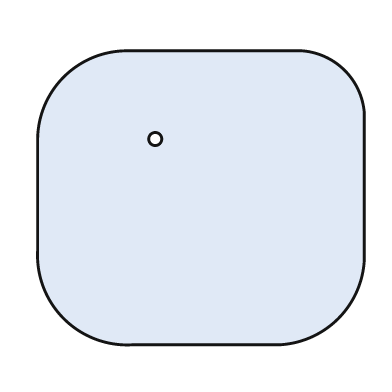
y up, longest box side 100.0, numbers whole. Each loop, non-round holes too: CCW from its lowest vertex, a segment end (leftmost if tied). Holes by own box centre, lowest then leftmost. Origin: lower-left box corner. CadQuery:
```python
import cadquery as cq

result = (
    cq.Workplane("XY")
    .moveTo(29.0, 0.0)
    .lineTo(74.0, 0.0)
    .threePointArc((92.0, 8.0), (100.0, 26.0))
    .lineTo(100.0, 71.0)
    .threePointArc((94.0, 84.0), (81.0, 90.0))
    .lineTo(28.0, 90.0)
    .threePointArc((8.0, 82.0), (0.0, 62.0))
    .lineTo(0.0, 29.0)
    .threePointArc((8.0, 8.0), (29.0, 0.0))
    .close()
    .moveTo(36.0, 63.0)
    .circle(2.0)
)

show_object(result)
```